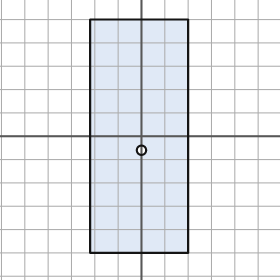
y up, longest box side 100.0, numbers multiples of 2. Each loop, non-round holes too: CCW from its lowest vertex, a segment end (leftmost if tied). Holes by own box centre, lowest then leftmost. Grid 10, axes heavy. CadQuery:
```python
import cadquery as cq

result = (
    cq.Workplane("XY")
    .moveTo(-22.0, -50.0)
    .lineTo(20.0, -50.0)
    .lineTo(20.0, 50.0)
    .lineTo(-22.0, 50.0)
    .close()
    .moveTo(0.0, -6.0)
    .circle(2.0)
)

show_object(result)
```